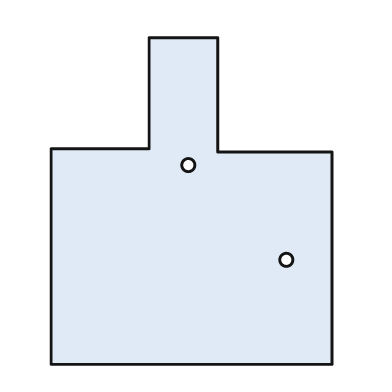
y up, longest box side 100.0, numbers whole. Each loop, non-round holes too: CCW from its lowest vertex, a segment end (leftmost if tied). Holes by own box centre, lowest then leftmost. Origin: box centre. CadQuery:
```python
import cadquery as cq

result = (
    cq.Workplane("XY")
    .moveTo(-43.0, -50.0)
    .lineTo(43.0, -50.0)
    .lineTo(43.0, 15.0)
    .lineTo(8.0, 15.0)
    .lineTo(8.0, 50.0)
    .lineTo(-13.0, 50.0)
    .lineTo(-13.0, 16.0)
    .lineTo(-43.0, 16.0)
    .close()
    .moveTo(29.0, -18.0)
    .circle(2.0)
    .moveTo(-1.0, 11.0)
    .circle(2.0)
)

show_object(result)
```